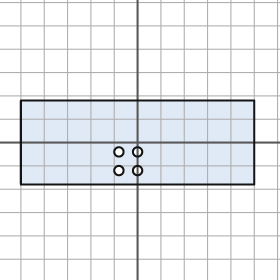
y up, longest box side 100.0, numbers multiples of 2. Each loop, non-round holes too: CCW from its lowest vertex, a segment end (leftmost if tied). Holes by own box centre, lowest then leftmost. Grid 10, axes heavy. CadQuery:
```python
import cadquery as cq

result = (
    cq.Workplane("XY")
    .moveTo(-50.0, -18.0)
    .lineTo(50.0, -18.0)
    .lineTo(50.0, 18.0)
    .lineTo(-50.0, 18.0)
    .close()
    .moveTo(-8.0, -12.0)
    .circle(2.0)
    .moveTo(0.0, -12.0)
    .circle(2.0)
    .moveTo(-8.0, -4.0)
    .circle(2.0)
    .moveTo(0.0, -4.0)
    .circle(2.0)
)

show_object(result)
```